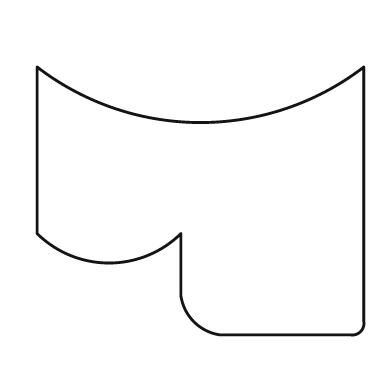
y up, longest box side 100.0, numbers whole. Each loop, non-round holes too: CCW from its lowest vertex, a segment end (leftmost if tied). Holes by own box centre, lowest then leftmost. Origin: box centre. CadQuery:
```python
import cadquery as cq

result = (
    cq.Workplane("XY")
    .moveTo(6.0, -41.0)
    .lineTo(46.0, -41.0)
    .threePointArc((49.0, -40.0), (50.0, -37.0))
    .lineTo(50.0, 41.0)
    .threePointArc((0.0, 24.0), (-50.0, 41.0))
    .lineTo(-50.0, -10.0)
    .threePointArc((-28.0, -19.0), (-6.0, -10.0))
    .lineTo(-6.0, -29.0)
    .threePointArc((-2.0, -37.0), (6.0, -41.0))
    .close()
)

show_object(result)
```